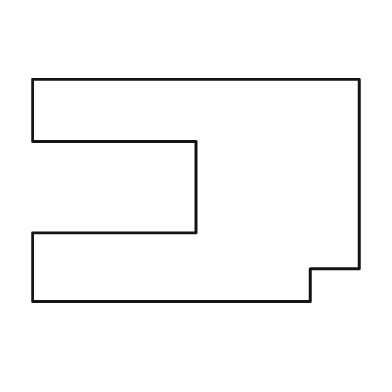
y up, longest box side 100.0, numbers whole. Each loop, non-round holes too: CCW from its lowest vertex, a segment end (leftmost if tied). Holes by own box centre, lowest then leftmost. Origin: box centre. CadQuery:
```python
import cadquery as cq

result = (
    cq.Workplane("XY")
    .moveTo(-50.0, -34.0)
    .lineTo(35.0, -34.0)
    .lineTo(35.0, -24.0)
    .lineTo(50.0, -24.0)
    .lineTo(50.0, 34.0)
    .lineTo(-50.0, 34.0)
    .lineTo(-50.0, 15.0)
    .lineTo(0.0, 15.0)
    .lineTo(0.0, -13.0)
    .lineTo(-50.0, -13.0)
    .close()
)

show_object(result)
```